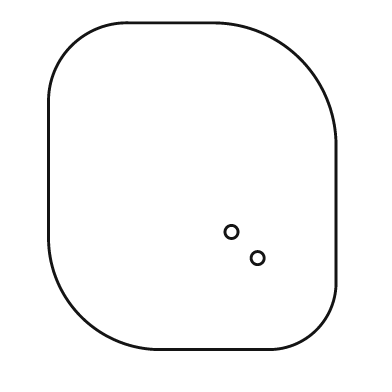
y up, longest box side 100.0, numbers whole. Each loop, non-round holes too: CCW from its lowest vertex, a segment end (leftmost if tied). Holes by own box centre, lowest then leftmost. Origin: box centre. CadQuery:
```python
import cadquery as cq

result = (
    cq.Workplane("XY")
    .moveTo(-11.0, -50.0)
    .lineTo(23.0, -50.0)
    .threePointArc((38.0, -44.0), (44.0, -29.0))
    .lineTo(44.0, 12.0)
    .threePointArc((33.0, 39.0), (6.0, 50.0))
    .lineTo(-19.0, 50.0)
    .threePointArc((-37.0, 43.0), (-44.0, 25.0))
    .lineTo(-44.0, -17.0)
    .threePointArc((-34.0, -40.0), (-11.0, -50.0))
    .close()
    .moveTo(20.0, -22.0)
    .circle(2.0)
    .moveTo(12.0, -14.0)
    .circle(2.0)
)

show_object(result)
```